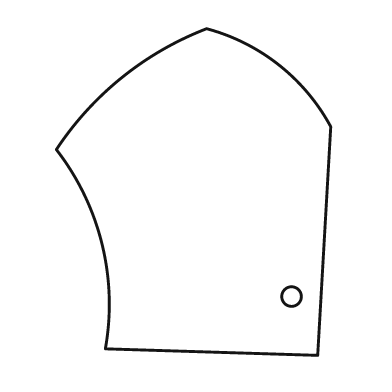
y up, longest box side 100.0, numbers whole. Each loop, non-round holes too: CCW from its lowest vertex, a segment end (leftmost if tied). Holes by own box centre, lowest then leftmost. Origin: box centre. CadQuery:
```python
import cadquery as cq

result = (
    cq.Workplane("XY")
    .moveTo(38.0, -50.0)
    .lineTo(42.0, 20.0)
    .threePointArc((26.0, 39.0), (4.0, 50.0))
    .threePointArc((-22.0, 35.0), (-42.0, 13.0))
    .threePointArc((-28.0, -16.0), (-27.0, -48.0))
    .close()
    .moveTo(30.0, -32.0)
    .circle(3.0)
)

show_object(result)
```